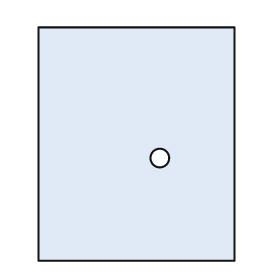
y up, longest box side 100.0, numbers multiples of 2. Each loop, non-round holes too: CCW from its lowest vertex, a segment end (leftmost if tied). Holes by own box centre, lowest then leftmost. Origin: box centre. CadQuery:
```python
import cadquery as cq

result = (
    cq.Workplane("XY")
    .moveTo(-42.0, -50.0)
    .lineTo(42.0, -50.0)
    .lineTo(42.0, 50.0)
    .lineTo(-42.0, 50.0)
    .close()
    .moveTo(10.0, -6.0)
    .circle(4.0)
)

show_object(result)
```